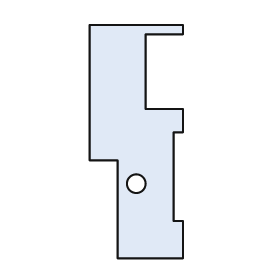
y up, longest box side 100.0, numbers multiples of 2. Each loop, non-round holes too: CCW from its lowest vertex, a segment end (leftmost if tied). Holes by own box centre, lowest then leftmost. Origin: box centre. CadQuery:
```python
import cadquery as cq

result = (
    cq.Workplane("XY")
    .moveTo(-8.0, -50.0)
    .lineTo(20.0, -50.0)
    .lineTo(20.0, -34.0)
    .lineTo(16.0, -34.0)
    .lineTo(16.0, 4.0)
    .lineTo(20.0, 4.0)
    .lineTo(20.0, 14.0)
    .lineTo(4.0, 14.0)
    .lineTo(4.0, 46.0)
    .lineTo(20.0, 46.0)
    .lineTo(20.0, 50.0)
    .lineTo(-20.0, 50.0)
    .lineTo(-20.0, -8.0)
    .lineTo(-8.0, -8.0)
    .close()
    .moveTo(0.0, -18.0)
    .circle(4.0)
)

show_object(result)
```